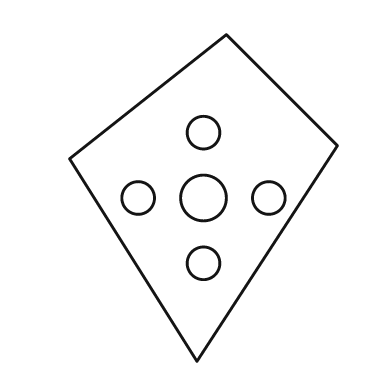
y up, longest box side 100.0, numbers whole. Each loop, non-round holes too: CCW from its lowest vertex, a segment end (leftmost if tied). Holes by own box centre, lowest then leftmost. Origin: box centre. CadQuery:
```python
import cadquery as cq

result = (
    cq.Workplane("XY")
    .moveTo(-2.0, -50.0)
    .lineTo(41.0, 16.0)
    .lineTo(7.0, 50.0)
    .lineTo(-41.0, 12.0)
    .close()
    .moveTo(0.0, -20.0)
    .circle(5.0)
    .moveTo(-20.0, 0.0)
    .circle(5.0)
    .moveTo(0.0, 0.0)
    .circle(7.0)
    .moveTo(20.0, 0.0)
    .circle(5.0)
    .moveTo(0.0, 20.0)
    .circle(5.0)
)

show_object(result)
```